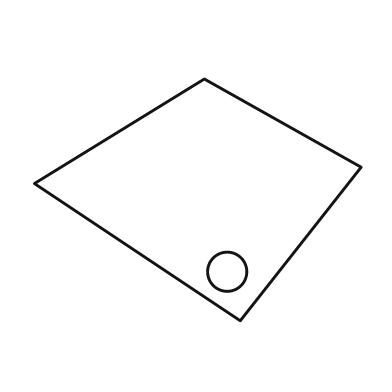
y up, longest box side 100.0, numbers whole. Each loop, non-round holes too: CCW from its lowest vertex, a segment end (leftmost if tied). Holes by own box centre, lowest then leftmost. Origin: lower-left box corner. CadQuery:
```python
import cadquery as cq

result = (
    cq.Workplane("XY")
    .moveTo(63.0, 0.0)
    .lineTo(100.0, 47.0)
    .lineTo(52.0, 74.0)
    .lineTo(0.0, 42.0)
    .close()
    .moveTo(59.0, 15.0)
    .circle(6.0)
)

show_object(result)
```